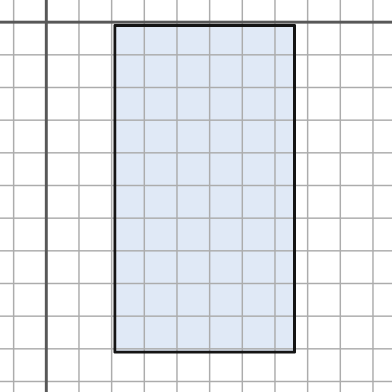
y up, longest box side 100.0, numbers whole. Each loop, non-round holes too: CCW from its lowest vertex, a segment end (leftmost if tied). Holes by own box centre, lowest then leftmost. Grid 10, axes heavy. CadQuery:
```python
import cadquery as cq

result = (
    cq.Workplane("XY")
    .moveTo(21.0, -101.0)
    .lineTo(76.0, -101.0)
    .lineTo(76.0, -1.0)
    .lineTo(21.0, -1.0)
    .close()
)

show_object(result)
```